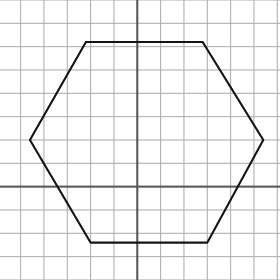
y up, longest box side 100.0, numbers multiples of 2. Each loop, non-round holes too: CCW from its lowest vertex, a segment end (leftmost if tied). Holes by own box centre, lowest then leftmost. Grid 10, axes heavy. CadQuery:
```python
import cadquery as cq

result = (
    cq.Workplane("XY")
    .moveTo(-20.0, -24.0)
    .lineTo(30.0, -24.0)
    .lineTo(54.0, 20.0)
    .lineTo(28.0, 62.0)
    .lineTo(-22.0, 62.0)
    .lineTo(-46.0, 20.0)
    .close()
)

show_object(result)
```